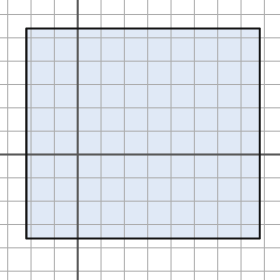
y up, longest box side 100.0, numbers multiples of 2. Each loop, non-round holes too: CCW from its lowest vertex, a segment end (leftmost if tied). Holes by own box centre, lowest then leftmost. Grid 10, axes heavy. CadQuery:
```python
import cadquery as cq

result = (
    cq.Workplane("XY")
    .moveTo(-22.0, -36.0)
    .lineTo(78.0, -36.0)
    .lineTo(78.0, 54.0)
    .lineTo(-22.0, 54.0)
    .close()
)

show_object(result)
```